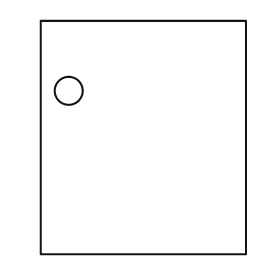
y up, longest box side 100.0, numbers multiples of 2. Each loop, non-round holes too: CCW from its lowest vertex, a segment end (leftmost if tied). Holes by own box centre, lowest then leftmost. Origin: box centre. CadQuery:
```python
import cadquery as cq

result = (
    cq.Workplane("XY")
    .moveTo(-44.0, -50.0)
    .lineTo(44.0, -50.0)
    .lineTo(44.0, 50.0)
    .lineTo(-44.0, 50.0)
    .close()
    .moveTo(-32.0, 20.0)
    .circle(6.0)
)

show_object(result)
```